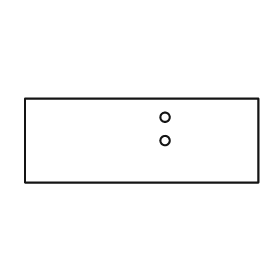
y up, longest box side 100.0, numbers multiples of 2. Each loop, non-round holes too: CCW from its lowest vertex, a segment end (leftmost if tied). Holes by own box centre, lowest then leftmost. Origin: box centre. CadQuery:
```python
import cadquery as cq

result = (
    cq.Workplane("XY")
    .moveTo(-50.0, -18.0)
    .lineTo(50.0, -18.0)
    .lineTo(50.0, 18.0)
    .lineTo(-50.0, 18.0)
    .close()
    .moveTo(10.0, 0.0)
    .circle(2.0)
    .moveTo(10.0, 10.0)
    .circle(2.0)
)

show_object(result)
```